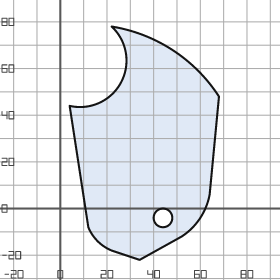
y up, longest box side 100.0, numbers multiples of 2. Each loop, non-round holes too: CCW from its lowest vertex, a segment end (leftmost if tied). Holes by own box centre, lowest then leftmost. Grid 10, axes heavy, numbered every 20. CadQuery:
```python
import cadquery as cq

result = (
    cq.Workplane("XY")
    .moveTo(34.0, -22.0)
    .lineTo(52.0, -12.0)
    .threePointArc((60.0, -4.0), (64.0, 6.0))
    .lineTo(68.0, 48.0)
    .threePointArc((48.0, 68.0), (22.0, 78.0))
    .threePointArc((26.0, 54.0), (4.0, 44.0))
    .lineTo(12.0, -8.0)
    .threePointArc((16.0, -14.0), (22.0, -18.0))
    .close()
    .moveTo(44.0, -4.0)
    .circle(4.0)
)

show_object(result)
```